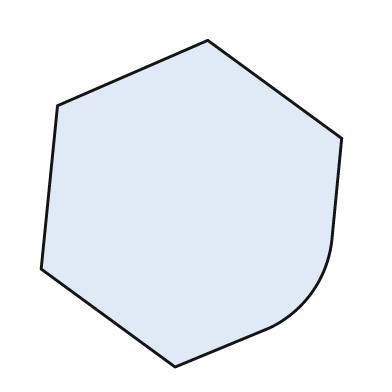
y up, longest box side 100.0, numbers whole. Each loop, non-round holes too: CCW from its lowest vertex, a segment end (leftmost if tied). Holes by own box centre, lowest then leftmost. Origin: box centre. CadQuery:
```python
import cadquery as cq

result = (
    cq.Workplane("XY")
    .moveTo(-5.0, -50.0)
    .lineTo(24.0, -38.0)
    .threePointArc((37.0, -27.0), (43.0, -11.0))
    .lineTo(46.0, 20.0)
    .lineTo(5.0, 50.0)
    .lineTo(-41.0, 30.0)
    .lineTo(-46.0, -20.0)
    .close()
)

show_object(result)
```